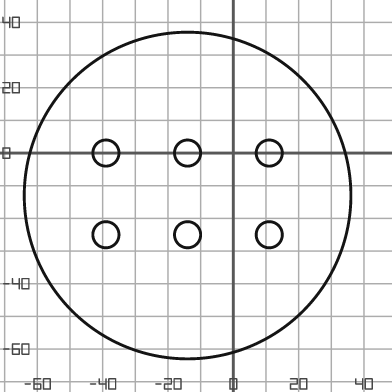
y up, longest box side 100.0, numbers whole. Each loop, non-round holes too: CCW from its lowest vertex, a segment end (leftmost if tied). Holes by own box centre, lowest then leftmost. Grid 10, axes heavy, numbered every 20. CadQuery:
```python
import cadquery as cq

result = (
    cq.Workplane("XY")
    .moveTo(-14.0, -13.0)
    .circle(50.0)
    .moveTo(-39.0, -25.0)
    .circle(4.0)
    .moveTo(-14.0, -25.0)
    .circle(4.0)
    .moveTo(11.0, -25.0)
    .circle(4.0)
    .moveTo(-39.0, 0.0)
    .circle(4.0)
    .moveTo(-14.0, 0.0)
    .circle(4.0)
    .moveTo(11.0, 0.0)
    .circle(4.0)
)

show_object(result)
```